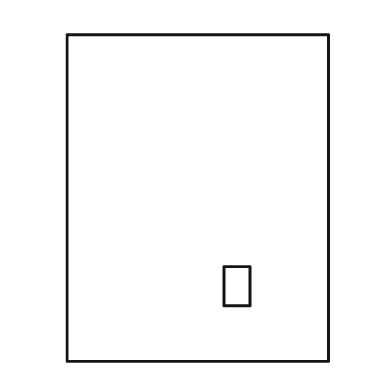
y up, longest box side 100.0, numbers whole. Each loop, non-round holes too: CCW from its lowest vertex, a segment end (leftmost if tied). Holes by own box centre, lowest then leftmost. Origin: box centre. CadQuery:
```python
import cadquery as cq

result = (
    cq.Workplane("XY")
    .moveTo(-40.0, -50.0)
    .lineTo(40.0, -50.0)
    .lineTo(40.0, 50.0)
    .lineTo(-40.0, 50.0)
    .close()
    .moveTo(8.0, -33.0)
    .lineTo(16.0, -33.0)
    .lineTo(16.0, -21.0)
    .lineTo(8.0, -21.0)
    .close()
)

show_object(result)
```